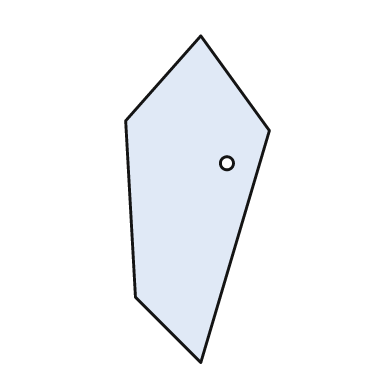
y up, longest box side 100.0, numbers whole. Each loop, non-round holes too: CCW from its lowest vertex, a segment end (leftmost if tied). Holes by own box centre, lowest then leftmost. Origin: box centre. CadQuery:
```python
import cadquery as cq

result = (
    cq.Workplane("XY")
    .moveTo(1.0, -50.0)
    .lineTo(22.0, 21.0)
    .lineTo(1.0, 50.0)
    .lineTo(-22.0, 24.0)
    .lineTo(-19.0, -30.0)
    .close()
    .moveTo(9.0, 11.0)
    .circle(2.0)
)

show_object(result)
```